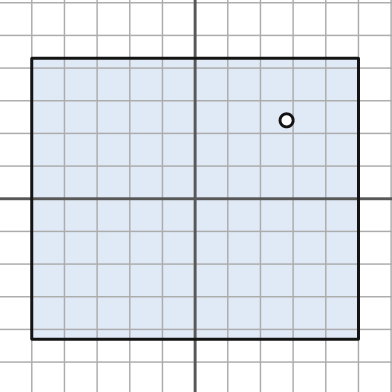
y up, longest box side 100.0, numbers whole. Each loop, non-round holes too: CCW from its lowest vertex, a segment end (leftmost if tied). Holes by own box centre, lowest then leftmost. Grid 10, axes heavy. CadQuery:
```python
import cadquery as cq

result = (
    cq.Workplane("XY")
    .moveTo(-50.0, -43.0)
    .lineTo(50.0, -43.0)
    .lineTo(50.0, 43.0)
    .lineTo(-50.0, 43.0)
    .close()
    .moveTo(28.0, 24.0)
    .circle(2.0)
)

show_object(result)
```